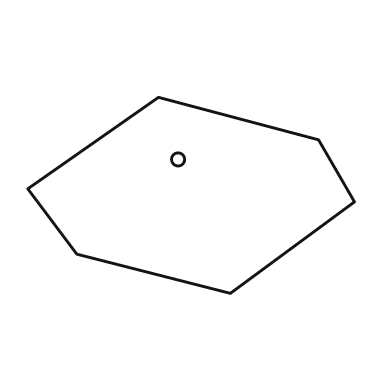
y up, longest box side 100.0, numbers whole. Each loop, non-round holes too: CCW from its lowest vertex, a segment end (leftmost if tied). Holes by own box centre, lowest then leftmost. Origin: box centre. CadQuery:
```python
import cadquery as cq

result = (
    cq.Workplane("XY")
    .moveTo(12.0, -30.0)
    .lineTo(50.0, -2.0)
    .lineTo(39.0, 17.0)
    .lineTo(-10.0, 30.0)
    .lineTo(-50.0, 2.0)
    .lineTo(-35.0, -18.0)
    .close()
    .moveTo(-4.0, 11.0)
    .circle(2.0)
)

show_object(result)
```